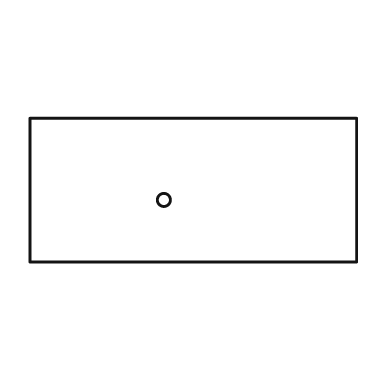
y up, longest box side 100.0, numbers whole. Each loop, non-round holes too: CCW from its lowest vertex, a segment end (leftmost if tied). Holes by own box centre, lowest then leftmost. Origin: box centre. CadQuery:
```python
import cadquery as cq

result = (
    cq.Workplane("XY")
    .moveTo(-50.0, -22.0)
    .lineTo(50.0, -22.0)
    .lineTo(50.0, 22.0)
    .lineTo(-50.0, 22.0)
    .close()
    .moveTo(-9.0, -3.0)
    .circle(2.0)
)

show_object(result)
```